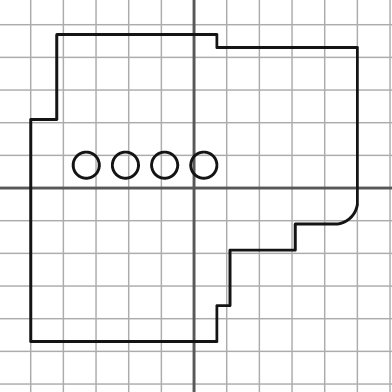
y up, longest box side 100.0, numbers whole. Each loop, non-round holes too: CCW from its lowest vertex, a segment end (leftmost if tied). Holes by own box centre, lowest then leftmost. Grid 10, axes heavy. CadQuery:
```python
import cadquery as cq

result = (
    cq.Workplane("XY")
    .moveTo(-50.0, -47.0)
    .lineTo(7.0, -47.0)
    .lineTo(7.0, -36.0)
    .lineTo(11.0, -36.0)
    .lineTo(11.0, -19.0)
    .lineTo(31.0, -19.0)
    .lineTo(31.0, -11.0)
    .lineTo(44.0, -11.0)
    .threePointArc((48.0, -9.0), (50.0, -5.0))
    .lineTo(50.0, 43.0)
    .lineTo(7.0, 43.0)
    .lineTo(7.0, 47.0)
    .lineTo(-42.0, 47.0)
    .lineTo(-42.0, 21.0)
    .lineTo(-50.0, 21.0)
    .close()
    .moveTo(-33.0, 7.0)
    .circle(4.0)
    .moveTo(-21.0, 7.0)
    .circle(4.0)
    .moveTo(-9.0, 7.0)
    .circle(4.0)
    .moveTo(3.0, 7.0)
    .circle(4.0)
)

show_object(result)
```